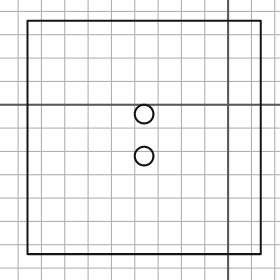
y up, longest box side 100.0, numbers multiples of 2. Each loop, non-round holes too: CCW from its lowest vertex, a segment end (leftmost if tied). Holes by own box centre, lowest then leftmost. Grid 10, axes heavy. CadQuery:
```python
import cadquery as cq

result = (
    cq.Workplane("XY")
    .moveTo(-86.0, -64.0)
    .lineTo(14.0, -64.0)
    .lineTo(14.0, 36.0)
    .lineTo(-86.0, 36.0)
    .close()
    .moveTo(-36.0, -22.0)
    .circle(4.0)
    .moveTo(-36.0, -4.0)
    .circle(4.0)
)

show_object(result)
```